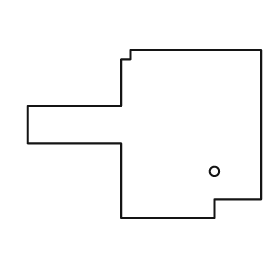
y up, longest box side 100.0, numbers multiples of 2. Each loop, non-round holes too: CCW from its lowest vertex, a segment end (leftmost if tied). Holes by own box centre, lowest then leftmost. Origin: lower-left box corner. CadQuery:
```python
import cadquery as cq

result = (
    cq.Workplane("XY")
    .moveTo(40.0, 0.0)
    .lineTo(80.0, 0.0)
    .lineTo(80.0, 8.0)
    .lineTo(100.0, 8.0)
    .lineTo(100.0, 72.0)
    .lineTo(44.0, 72.0)
    .lineTo(44.0, 68.0)
    .lineTo(40.0, 68.0)
    .lineTo(40.0, 48.0)
    .lineTo(0.0, 48.0)
    .lineTo(0.0, 32.0)
    .lineTo(40.0, 32.0)
    .close()
    .moveTo(80.0, 20.0)
    .circle(2.0)
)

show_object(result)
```